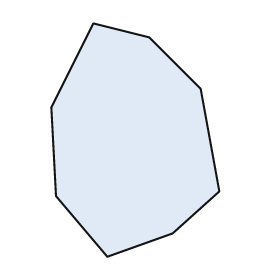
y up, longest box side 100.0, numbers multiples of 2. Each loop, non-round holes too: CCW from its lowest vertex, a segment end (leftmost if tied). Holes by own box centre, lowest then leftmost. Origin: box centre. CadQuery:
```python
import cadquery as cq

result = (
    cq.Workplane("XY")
    .moveTo(-12.0, -50.0)
    .lineTo(16.0, -40.0)
    .lineTo(36.0, -22.0)
    .lineTo(28.0, 22.0)
    .lineTo(6.0, 44.0)
    .lineTo(-18.0, 50.0)
    .lineTo(-36.0, 14.0)
    .lineTo(-34.0, -24.0)
    .close()
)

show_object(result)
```